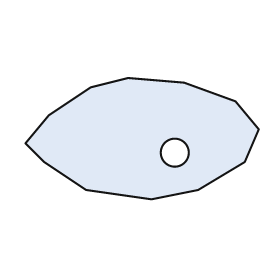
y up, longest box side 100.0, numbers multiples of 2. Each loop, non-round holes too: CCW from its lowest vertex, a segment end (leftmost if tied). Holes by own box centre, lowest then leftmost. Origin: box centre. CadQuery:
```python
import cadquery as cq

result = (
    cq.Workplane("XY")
    .moveTo(4.0, -26.0)
    .lineTo(24.0, -22.0)
    .lineTo(44.0, -10.0)
    .lineTo(50.0, 4.0)
    .lineTo(40.0, 16.0)
    .lineTo(18.0, 24.0)
    .lineTo(-6.0, 26.0)
    .lineTo(-22.0, 22.0)
    .lineTo(-40.0, 10.0)
    .lineTo(-50.0, -2.0)
    .lineTo(-42.0, -10.0)
    .lineTo(-24.0, -22.0)
    .close()
    .moveTo(14.0, -6.0)
    .circle(6.0)
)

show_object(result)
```